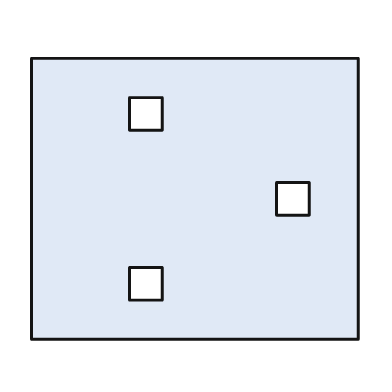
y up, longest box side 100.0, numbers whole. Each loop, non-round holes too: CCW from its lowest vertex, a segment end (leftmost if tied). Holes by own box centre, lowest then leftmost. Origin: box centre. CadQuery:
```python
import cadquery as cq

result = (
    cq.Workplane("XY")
    .moveTo(-50.0, -43.0)
    .lineTo(50.0, -43.0)
    .lineTo(50.0, 43.0)
    .lineTo(-50.0, 43.0)
    .close()
    .moveTo(-20.0, -31.0)
    .lineTo(-10.0, -31.0)
    .lineTo(-10.0, -21.0)
    .lineTo(-20.0, -21.0)
    .close()
    .moveTo(25.0, -5.0)
    .lineTo(35.0, -5.0)
    .lineTo(35.0, 5.0)
    .lineTo(25.0, 5.0)
    .close()
    .moveTo(-20.0, 21.0)
    .lineTo(-10.0, 21.0)
    .lineTo(-10.0, 31.0)
    .lineTo(-20.0, 31.0)
    .close()
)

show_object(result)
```